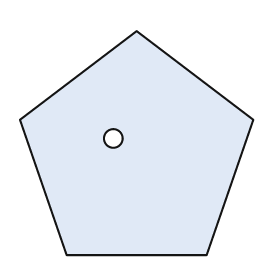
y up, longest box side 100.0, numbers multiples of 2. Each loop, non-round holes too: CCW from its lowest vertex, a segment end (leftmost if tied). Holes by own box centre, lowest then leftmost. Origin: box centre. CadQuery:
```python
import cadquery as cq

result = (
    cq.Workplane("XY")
    .moveTo(-30.0, -48.0)
    .lineTo(30.0, -48.0)
    .lineTo(50.0, 10.0)
    .lineTo(0.0, 48.0)
    .lineTo(-50.0, 10.0)
    .close()
    .moveTo(-10.0, 2.0)
    .circle(4.0)
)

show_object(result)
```